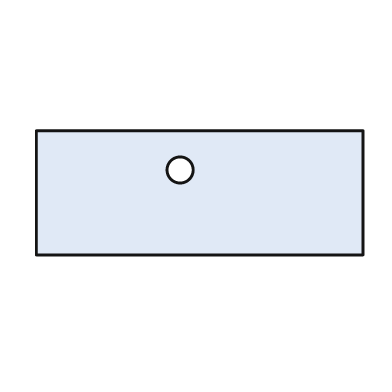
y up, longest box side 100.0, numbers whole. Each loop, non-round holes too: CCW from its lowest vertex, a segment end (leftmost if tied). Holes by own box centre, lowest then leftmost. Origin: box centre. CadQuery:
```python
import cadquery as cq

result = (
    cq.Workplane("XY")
    .moveTo(-50.0, -19.0)
    .lineTo(50.0, -19.0)
    .lineTo(50.0, 19.0)
    .lineTo(-50.0, 19.0)
    .close()
    .moveTo(-6.0, 7.0)
    .circle(4.0)
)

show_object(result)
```